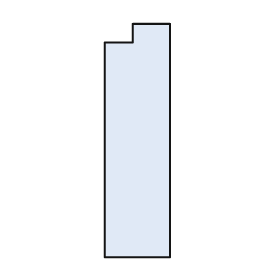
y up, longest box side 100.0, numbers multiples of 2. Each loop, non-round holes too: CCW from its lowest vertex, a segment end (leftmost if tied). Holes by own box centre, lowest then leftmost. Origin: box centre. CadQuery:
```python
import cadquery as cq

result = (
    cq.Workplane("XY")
    .moveTo(-14.0, -50.0)
    .lineTo(14.0, -50.0)
    .lineTo(14.0, 50.0)
    .lineTo(-2.0, 50.0)
    .lineTo(-2.0, 42.0)
    .lineTo(-14.0, 42.0)
    .close()
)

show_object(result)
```